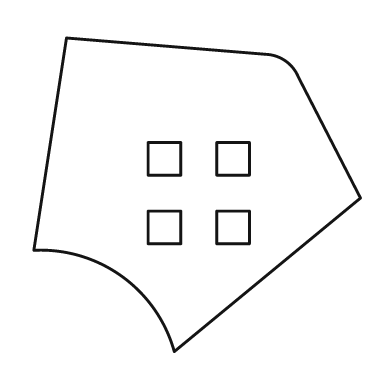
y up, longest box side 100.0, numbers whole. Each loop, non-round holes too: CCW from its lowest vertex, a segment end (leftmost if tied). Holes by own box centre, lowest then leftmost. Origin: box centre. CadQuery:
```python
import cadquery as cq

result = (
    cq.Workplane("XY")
    .moveTo(-7.0, -48.0)
    .lineTo(50.0, -1.0)
    .lineTo(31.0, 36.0)
    .threePointArc((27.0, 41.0), (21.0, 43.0))
    .lineTo(-40.0, 48.0)
    .lineTo(-50.0, -17.0)
    .threePointArc((-23.0, -25.0), (-7.0, -48.0))
    .close()
    .moveTo(-15.0, -15.0)
    .lineTo(-5.0, -15.0)
    .lineTo(-5.0, -5.0)
    .lineTo(-15.0, -5.0)
    .close()
    .moveTo(6.0, -15.0)
    .lineTo(16.0, -15.0)
    .lineTo(16.0, -5.0)
    .lineTo(6.0, -5.0)
    .close()
    .moveTo(-15.0, 6.0)
    .lineTo(-5.0, 6.0)
    .lineTo(-5.0, 16.0)
    .lineTo(-15.0, 16.0)
    .close()
    .moveTo(6.0, 6.0)
    .lineTo(16.0, 6.0)
    .lineTo(16.0, 16.0)
    .lineTo(6.0, 16.0)
    .close()
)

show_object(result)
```